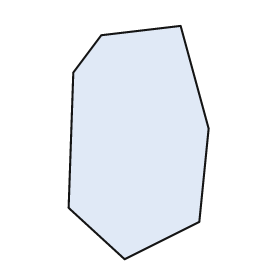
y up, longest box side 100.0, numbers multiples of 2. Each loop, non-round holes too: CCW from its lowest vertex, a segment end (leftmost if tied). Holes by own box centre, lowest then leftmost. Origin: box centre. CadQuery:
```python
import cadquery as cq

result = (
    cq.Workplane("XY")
    .moveTo(-6.0, -50.0)
    .lineTo(26.0, -34.0)
    .lineTo(30.0, 6.0)
    .lineTo(18.0, 50.0)
    .lineTo(-16.0, 46.0)
    .lineTo(-28.0, 30.0)
    .lineTo(-30.0, -28.0)
    .close()
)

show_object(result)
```